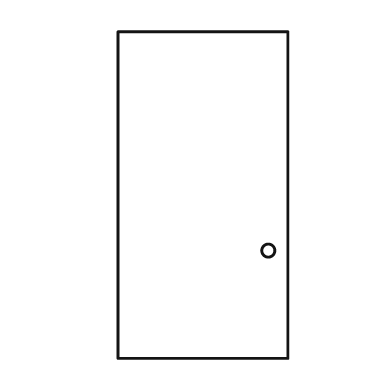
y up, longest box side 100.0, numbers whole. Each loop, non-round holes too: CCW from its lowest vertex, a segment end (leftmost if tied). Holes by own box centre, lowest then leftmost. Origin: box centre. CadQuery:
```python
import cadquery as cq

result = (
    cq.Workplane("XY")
    .moveTo(-26.0, -50.0)
    .lineTo(26.0, -50.0)
    .lineTo(26.0, 50.0)
    .lineTo(-26.0, 50.0)
    .close()
    .moveTo(20.0, -17.0)
    .circle(2.0)
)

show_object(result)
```